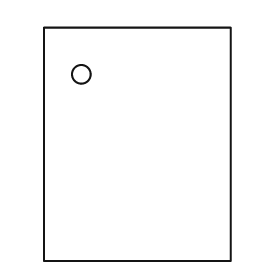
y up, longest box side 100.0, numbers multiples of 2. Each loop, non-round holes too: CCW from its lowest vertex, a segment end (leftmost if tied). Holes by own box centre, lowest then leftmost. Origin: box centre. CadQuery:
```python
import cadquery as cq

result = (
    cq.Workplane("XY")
    .moveTo(-40.0, -50.0)
    .lineTo(40.0, -50.0)
    .lineTo(40.0, 50.0)
    .lineTo(-40.0, 50.0)
    .close()
    .moveTo(-24.0, 30.0)
    .circle(4.0)
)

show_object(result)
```